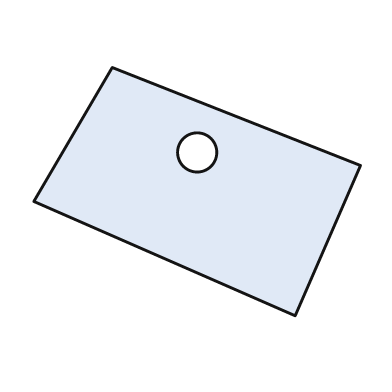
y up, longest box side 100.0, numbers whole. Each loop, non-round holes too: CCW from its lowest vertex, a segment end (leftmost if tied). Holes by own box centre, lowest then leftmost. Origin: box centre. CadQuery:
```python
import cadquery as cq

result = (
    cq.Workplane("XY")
    .moveTo(30.0, -38.0)
    .lineTo(50.0, 8.0)
    .lineTo(-26.0, 38.0)
    .lineTo(-50.0, -3.0)
    .close()
    .moveTo(0.0, 12.0)
    .circle(6.0)
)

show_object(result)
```